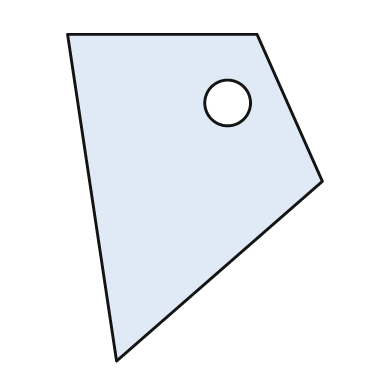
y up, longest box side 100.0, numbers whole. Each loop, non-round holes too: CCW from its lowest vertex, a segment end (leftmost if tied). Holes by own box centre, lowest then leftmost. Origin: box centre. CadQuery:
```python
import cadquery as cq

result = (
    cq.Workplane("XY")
    .moveTo(-24.0, -50.0)
    .lineTo(39.0, 5.0)
    .lineTo(19.0, 50.0)
    .lineTo(-39.0, 50.0)
    .close()
    .moveTo(10.0, 29.0)
    .circle(7.0)
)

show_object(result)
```